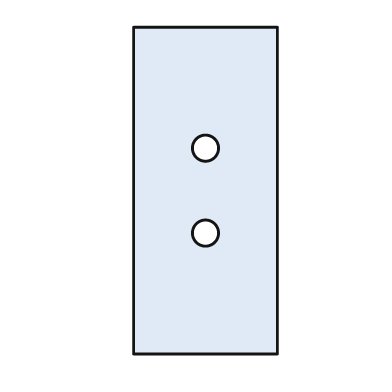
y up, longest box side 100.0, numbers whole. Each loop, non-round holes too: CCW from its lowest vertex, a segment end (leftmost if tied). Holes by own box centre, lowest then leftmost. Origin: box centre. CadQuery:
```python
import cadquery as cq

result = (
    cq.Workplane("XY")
    .moveTo(-22.0, -50.0)
    .lineTo(22.0, -50.0)
    .lineTo(22.0, 50.0)
    .lineTo(-22.0, 50.0)
    .close()
    .moveTo(0.0, -13.0)
    .circle(4.0)
    .moveTo(0.0, 13.0)
    .circle(4.0)
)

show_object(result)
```